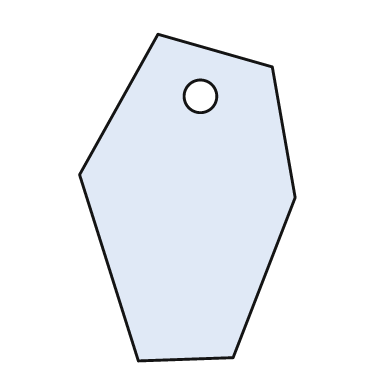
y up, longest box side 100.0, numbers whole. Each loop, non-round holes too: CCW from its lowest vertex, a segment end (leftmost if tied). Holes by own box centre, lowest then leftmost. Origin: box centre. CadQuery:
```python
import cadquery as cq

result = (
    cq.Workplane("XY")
    .moveTo(-15.0, -50.0)
    .lineTo(14.0, -49.0)
    .lineTo(33.0, 0.0)
    .lineTo(26.0, 40.0)
    .lineTo(-9.0, 50.0)
    .lineTo(-33.0, 7.0)
    .close()
    .moveTo(4.0, 31.0)
    .circle(5.0)
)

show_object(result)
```